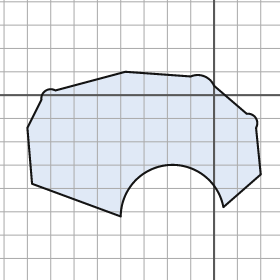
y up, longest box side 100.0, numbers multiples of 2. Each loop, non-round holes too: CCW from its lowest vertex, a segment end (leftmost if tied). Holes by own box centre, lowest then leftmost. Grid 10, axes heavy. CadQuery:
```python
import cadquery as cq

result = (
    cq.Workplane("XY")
    .moveTo(-40.0, -52.0)
    .threePointArc((-20.0, -30.0), (4.0, -48.0))
    .lineTo(20.0, -34.0)
    .lineTo(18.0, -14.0)
    .threePointArc((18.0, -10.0), (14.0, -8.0))
    .lineTo(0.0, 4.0)
    .threePointArc((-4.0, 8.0), (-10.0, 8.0))
    .lineTo(-38.0, 10.0)
    .lineTo(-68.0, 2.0)
    .threePointArc((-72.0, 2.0), (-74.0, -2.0))
    .lineTo(-80.0, -14.0)
    .lineTo(-78.0, -38.0)
    .close()
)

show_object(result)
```